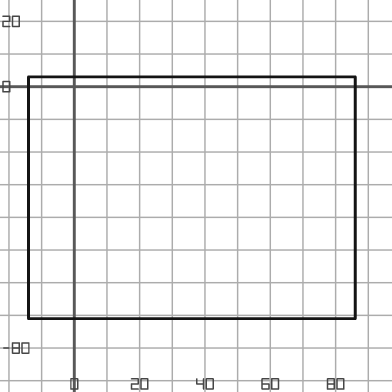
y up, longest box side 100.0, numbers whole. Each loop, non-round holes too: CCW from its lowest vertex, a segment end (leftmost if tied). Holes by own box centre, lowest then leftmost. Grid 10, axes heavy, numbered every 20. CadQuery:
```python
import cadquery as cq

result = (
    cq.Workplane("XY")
    .moveTo(-14.0, -71.0)
    .lineTo(86.0, -71.0)
    .lineTo(86.0, 3.0)
    .lineTo(-14.0, 3.0)
    .close()
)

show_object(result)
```